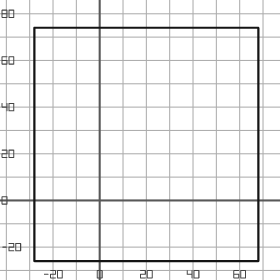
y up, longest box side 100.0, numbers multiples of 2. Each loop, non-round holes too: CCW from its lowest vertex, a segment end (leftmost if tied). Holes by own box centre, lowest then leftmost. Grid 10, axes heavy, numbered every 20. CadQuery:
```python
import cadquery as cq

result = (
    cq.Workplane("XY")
    .moveTo(-28.0, -26.0)
    .lineTo(68.0, -26.0)
    .lineTo(68.0, 74.0)
    .lineTo(-28.0, 74.0)
    .close()
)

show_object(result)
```